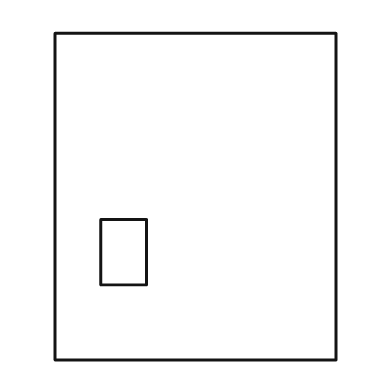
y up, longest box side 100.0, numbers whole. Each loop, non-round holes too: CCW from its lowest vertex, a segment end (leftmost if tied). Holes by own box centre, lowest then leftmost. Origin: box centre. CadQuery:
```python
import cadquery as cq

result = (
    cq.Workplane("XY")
    .moveTo(-43.0, -50.0)
    .lineTo(43.0, -50.0)
    .lineTo(43.0, 50.0)
    .lineTo(-43.0, 50.0)
    .close()
    .moveTo(-29.0, -27.0)
    .lineTo(-15.0, -27.0)
    .lineTo(-15.0, -7.0)
    .lineTo(-29.0, -7.0)
    .close()
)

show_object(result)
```